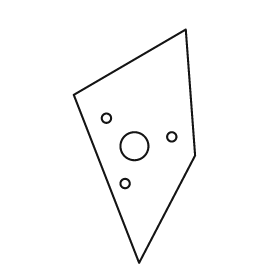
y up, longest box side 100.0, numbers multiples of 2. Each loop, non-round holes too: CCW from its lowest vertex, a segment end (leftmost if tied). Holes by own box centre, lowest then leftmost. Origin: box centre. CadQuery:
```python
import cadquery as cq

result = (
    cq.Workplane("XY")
    .moveTo(2.0, -50.0)
    .lineTo(26.0, -4.0)
    .lineTo(22.0, 50.0)
    .lineTo(-26.0, 22.0)
    .close()
    .moveTo(-4.0, -16.0)
    .circle(2.0)
    .moveTo(0.0, 0.0)
    .circle(6.0)
    .moveTo(16.0, 4.0)
    .circle(2.0)
    .moveTo(-12.0, 12.0)
    .circle(2.0)
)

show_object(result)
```